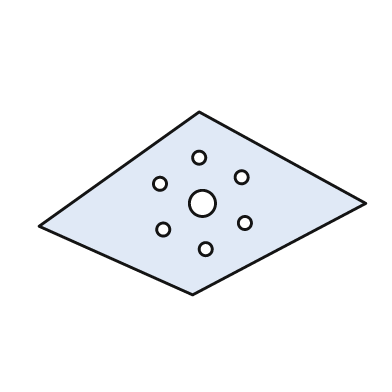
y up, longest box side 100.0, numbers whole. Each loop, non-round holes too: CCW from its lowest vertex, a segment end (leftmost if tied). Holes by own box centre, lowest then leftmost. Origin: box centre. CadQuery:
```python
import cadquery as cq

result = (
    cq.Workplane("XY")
    .moveTo(-3.0, -28.0)
    .lineTo(50.0, 0.0)
    .lineTo(-1.0, 28.0)
    .lineTo(-50.0, -7.0)
    .close()
    .moveTo(1.0, -14.0)
    .circle(2.0)
    .moveTo(-12.0, -8.0)
    .circle(2.0)
    .moveTo(13.0, -6.0)
    .circle(2.0)
    .moveTo(0.0, 0.0)
    .circle(4.0)
    .moveTo(-13.0, 6.0)
    .circle(2.0)
    .moveTo(12.0, 8.0)
    .circle(2.0)
    .moveTo(-1.0, 14.0)
    .circle(2.0)
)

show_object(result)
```